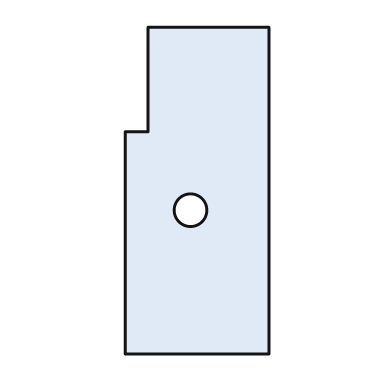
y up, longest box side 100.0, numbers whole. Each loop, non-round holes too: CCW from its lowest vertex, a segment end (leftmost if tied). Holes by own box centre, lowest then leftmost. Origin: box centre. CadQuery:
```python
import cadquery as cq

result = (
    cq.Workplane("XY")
    .moveTo(-22.0, -50.0)
    .lineTo(22.0, -50.0)
    .lineTo(22.0, 50.0)
    .lineTo(-15.0, 50.0)
    .lineTo(-15.0, 18.0)
    .lineTo(-22.0, 18.0)
    .close()
    .moveTo(-2.0, -6.0)
    .circle(5.0)
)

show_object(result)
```